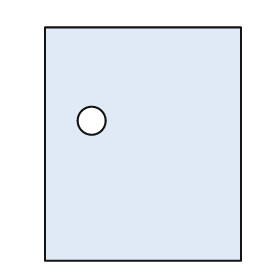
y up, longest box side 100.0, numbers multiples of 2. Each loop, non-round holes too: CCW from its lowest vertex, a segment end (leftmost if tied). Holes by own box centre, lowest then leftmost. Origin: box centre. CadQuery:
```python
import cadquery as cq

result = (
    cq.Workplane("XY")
    .moveTo(-42.0, -50.0)
    .lineTo(42.0, -50.0)
    .lineTo(42.0, 50.0)
    .lineTo(-42.0, 50.0)
    .close()
    .moveTo(-22.0, 10.0)
    .circle(6.0)
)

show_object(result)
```